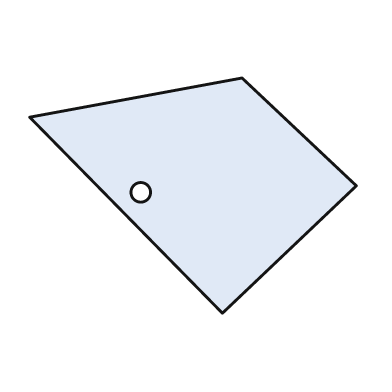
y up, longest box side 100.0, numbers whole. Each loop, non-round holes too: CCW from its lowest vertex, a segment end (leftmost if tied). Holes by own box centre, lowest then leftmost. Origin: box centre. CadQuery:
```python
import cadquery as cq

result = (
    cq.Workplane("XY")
    .moveTo(9.0, -36.0)
    .lineTo(50.0, 3.0)
    .lineTo(15.0, 36.0)
    .lineTo(-50.0, 24.0)
    .close()
    .moveTo(-16.0, 1.0)
    .circle(3.0)
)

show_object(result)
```